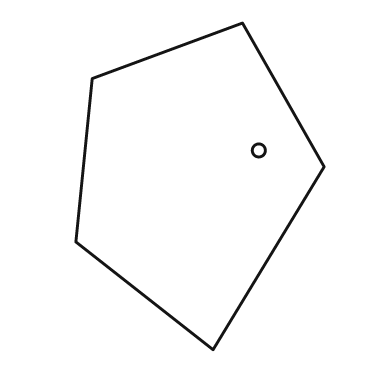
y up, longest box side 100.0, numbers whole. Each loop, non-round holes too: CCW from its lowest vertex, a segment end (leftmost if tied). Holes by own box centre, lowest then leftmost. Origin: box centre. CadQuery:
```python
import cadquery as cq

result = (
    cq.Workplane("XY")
    .moveTo(4.0, -50.0)
    .lineTo(38.0, 6.0)
    .lineTo(13.0, 50.0)
    .lineTo(-33.0, 33.0)
    .lineTo(-38.0, -17.0)
    .close()
    .moveTo(18.0, 11.0)
    .circle(2.0)
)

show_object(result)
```